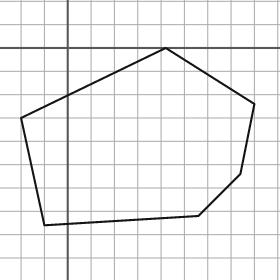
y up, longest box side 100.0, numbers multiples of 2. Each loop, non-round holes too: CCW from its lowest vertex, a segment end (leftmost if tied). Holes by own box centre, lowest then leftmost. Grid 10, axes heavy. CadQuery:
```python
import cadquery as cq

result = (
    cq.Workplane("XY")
    .moveTo(-10.0, -76.0)
    .lineTo(56.0, -72.0)
    .lineTo(74.0, -54.0)
    .lineTo(80.0, -24.0)
    .lineTo(42.0, 0.0)
    .lineTo(-20.0, -30.0)
    .close()
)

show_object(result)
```